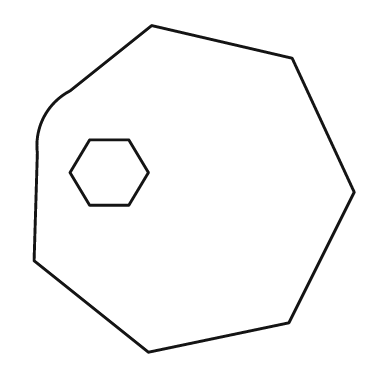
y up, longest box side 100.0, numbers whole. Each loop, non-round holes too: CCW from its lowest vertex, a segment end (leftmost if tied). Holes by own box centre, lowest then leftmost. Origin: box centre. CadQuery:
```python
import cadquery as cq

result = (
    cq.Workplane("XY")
    .moveTo(-14.0, -50.0)
    .lineTo(29.0, -41.0)
    .lineTo(49.0, -1.0)
    .lineTo(30.0, 40.0)
    .lineTo(-13.0, 50.0)
    .lineTo(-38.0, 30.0)
    .threePointArc((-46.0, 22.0), (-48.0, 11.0))
    .lineTo(-49.0, -22.0)
    .close()
    .moveTo(-32.0, -5.0)
    .lineTo(-20.0, -5.0)
    .lineTo(-14.0, 5.0)
    .lineTo(-20.0, 15.0)
    .lineTo(-32.0, 15.0)
    .lineTo(-38.0, 5.0)
    .close()
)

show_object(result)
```